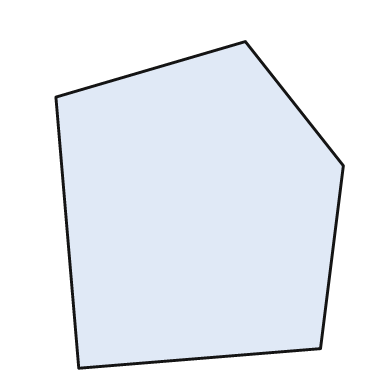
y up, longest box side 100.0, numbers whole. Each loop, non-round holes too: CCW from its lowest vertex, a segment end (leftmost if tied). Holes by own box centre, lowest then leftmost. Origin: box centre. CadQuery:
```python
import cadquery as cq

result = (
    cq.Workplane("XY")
    .moveTo(-37.0, -50.0)
    .lineTo(37.0, -44.0)
    .lineTo(44.0, 12.0)
    .lineTo(14.0, 50.0)
    .lineTo(-44.0, 33.0)
    .close()
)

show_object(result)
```